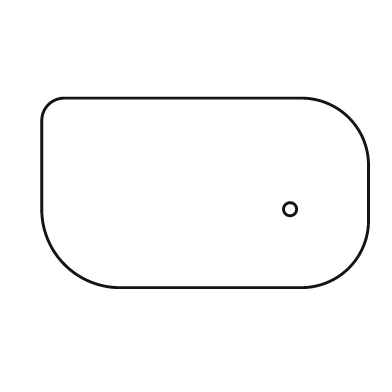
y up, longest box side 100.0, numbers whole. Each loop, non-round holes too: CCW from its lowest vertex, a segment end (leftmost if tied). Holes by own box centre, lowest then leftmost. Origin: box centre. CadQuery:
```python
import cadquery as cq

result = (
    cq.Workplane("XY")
    .moveTo(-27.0, -29.0)
    .lineTo(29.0, -29.0)
    .threePointArc((44.0, -23.0), (50.0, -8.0))
    .lineTo(50.0, 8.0)
    .threePointArc((44.0, 23.0), (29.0, 29.0))
    .lineTo(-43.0, 29.0)
    .threePointArc((-48.0, 27.0), (-50.0, 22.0))
    .lineTo(-50.0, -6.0)
    .threePointArc((-43.0, -22.0), (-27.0, -29.0))
    .close()
    .moveTo(26.0, -5.0)
    .circle(2.0)
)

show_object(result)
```